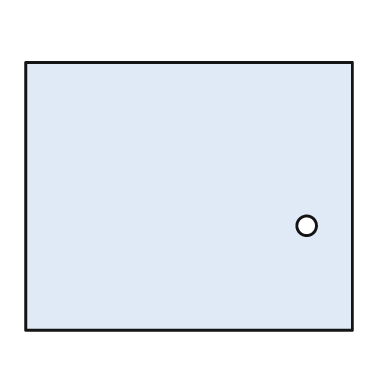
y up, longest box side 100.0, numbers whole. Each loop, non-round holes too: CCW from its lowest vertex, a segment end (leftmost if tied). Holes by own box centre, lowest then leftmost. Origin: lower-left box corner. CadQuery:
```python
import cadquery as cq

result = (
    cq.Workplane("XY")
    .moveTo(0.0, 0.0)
    .lineTo(100.0, 0.0)
    .lineTo(100.0, 82.0)
    .lineTo(0.0, 82.0)
    .close()
    .moveTo(86.0, 32.0)
    .circle(3.0)
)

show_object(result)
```